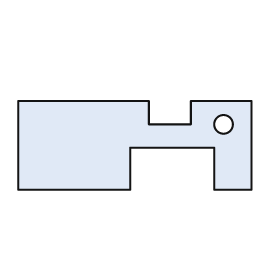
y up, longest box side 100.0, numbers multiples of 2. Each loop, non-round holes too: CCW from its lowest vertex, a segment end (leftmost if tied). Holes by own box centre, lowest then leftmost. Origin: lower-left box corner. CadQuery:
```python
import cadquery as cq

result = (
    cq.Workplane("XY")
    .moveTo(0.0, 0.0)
    .lineTo(48.0, 0.0)
    .lineTo(48.0, 18.0)
    .lineTo(84.0, 18.0)
    .lineTo(84.0, 0.0)
    .lineTo(100.0, 0.0)
    .lineTo(100.0, 38.0)
    .lineTo(74.0, 38.0)
    .lineTo(74.0, 28.0)
    .lineTo(56.0, 28.0)
    .lineTo(56.0, 38.0)
    .lineTo(0.0, 38.0)
    .close()
    .moveTo(88.0, 28.0)
    .circle(4.0)
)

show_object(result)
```